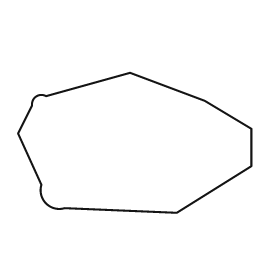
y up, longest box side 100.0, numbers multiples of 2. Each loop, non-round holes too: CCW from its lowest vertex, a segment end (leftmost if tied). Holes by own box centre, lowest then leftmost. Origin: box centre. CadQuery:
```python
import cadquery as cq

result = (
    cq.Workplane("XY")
    .moveTo(18.0, -30.0)
    .lineTo(50.0, -10.0)
    .lineTo(50.0, 6.0)
    .lineTo(30.0, 18.0)
    .lineTo(-2.0, 30.0)
    .lineTo(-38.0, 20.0)
    .threePointArc((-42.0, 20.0), (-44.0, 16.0))
    .lineTo(-50.0, 4.0)
    .lineTo(-40.0, -18.0)
    .threePointArc((-38.0, -26.0), (-30.0, -28.0))
    .close()
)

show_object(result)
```